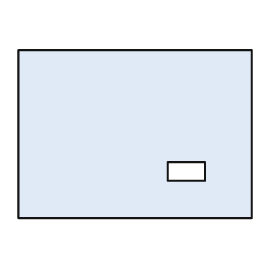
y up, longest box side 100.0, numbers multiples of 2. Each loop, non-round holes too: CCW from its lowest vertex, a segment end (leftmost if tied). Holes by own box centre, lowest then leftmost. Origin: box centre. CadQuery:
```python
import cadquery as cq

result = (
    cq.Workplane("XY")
    .moveTo(-50.0, -36.0)
    .lineTo(50.0, -36.0)
    .lineTo(50.0, 36.0)
    .lineTo(-50.0, 36.0)
    .close()
    .moveTo(14.0, -20.0)
    .lineTo(30.0, -20.0)
    .lineTo(30.0, -12.0)
    .lineTo(14.0, -12.0)
    .close()
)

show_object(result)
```